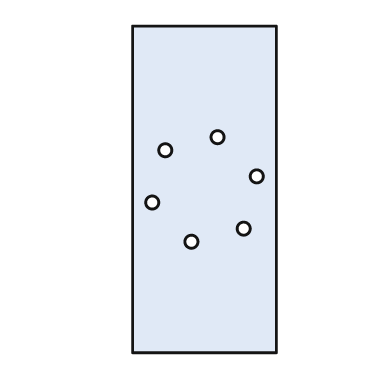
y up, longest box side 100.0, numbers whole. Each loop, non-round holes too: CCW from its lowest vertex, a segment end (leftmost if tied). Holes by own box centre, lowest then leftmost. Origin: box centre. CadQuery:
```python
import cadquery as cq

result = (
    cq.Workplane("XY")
    .moveTo(-22.0, -50.0)
    .lineTo(22.0, -50.0)
    .lineTo(22.0, 50.0)
    .lineTo(-22.0, 50.0)
    .close()
    .moveTo(-4.0, -16.0)
    .circle(2.0)
    .moveTo(12.0, -12.0)
    .circle(2.0)
    .moveTo(-16.0, -4.0)
    .circle(2.0)
    .moveTo(16.0, 4.0)
    .circle(2.0)
    .moveTo(-12.0, 12.0)
    .circle(2.0)
    .moveTo(4.0, 16.0)
    .circle(2.0)
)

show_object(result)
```